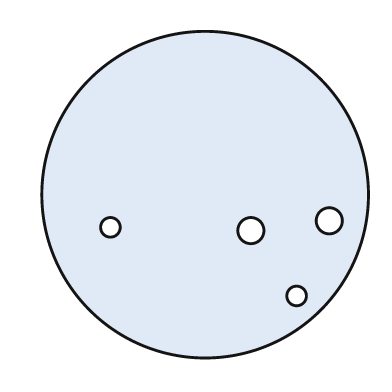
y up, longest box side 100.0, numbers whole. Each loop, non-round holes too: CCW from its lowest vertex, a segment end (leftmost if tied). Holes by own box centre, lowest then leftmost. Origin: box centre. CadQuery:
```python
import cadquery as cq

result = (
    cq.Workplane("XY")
    .moveTo(0.0, 0.0)
    .circle(50.0)
    .moveTo(28.0, -31.0)
    .circle(3.0)
    .moveTo(14.0, -11.0)
    .circle(4.0)
    .moveTo(-29.0, -10.0)
    .circle(3.0)
    .moveTo(38.0, -8.0)
    .circle(4.0)
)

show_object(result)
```